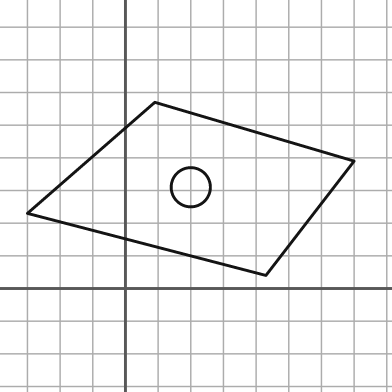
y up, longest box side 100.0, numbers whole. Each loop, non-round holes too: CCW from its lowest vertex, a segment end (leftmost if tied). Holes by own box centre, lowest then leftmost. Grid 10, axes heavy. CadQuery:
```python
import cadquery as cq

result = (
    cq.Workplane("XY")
    .moveTo(43.0, 4.0)
    .lineTo(70.0, 39.0)
    .lineTo(9.0, 57.0)
    .lineTo(-30.0, 23.0)
    .close()
    .moveTo(20.0, 31.0)
    .circle(6.0)
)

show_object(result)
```